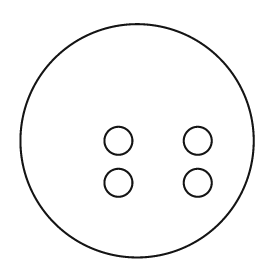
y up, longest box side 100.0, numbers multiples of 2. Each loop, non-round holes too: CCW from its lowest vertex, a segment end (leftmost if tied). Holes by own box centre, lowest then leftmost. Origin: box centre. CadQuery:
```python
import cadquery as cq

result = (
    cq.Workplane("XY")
    .moveTo(0.0, 0.0)
    .circle(50.0)
    .moveTo(-8.0, -18.0)
    .circle(6.0)
    .moveTo(26.0, -18.0)
    .circle(6.0)
    .moveTo(-8.0, 0.0)
    .circle(6.0)
    .moveTo(26.0, 0.0)
    .circle(6.0)
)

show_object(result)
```